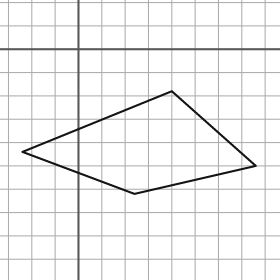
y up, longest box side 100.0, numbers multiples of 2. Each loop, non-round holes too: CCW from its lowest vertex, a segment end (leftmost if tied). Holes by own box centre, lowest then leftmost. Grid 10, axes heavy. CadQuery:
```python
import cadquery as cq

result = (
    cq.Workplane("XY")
    .moveTo(24.0, -62.0)
    .lineTo(76.0, -50.0)
    .lineTo(40.0, -18.0)
    .lineTo(-24.0, -44.0)
    .close()
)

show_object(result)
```